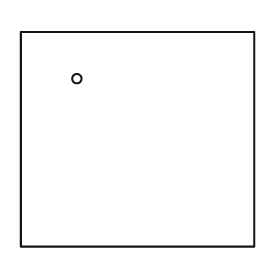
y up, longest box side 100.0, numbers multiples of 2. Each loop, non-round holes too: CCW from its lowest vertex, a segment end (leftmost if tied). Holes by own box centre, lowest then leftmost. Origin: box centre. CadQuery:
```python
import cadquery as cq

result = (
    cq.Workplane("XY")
    .moveTo(-50.0, -46.0)
    .lineTo(50.0, -46.0)
    .lineTo(50.0, 46.0)
    .lineTo(-50.0, 46.0)
    .close()
    .moveTo(-26.0, 26.0)
    .circle(2.0)
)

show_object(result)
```